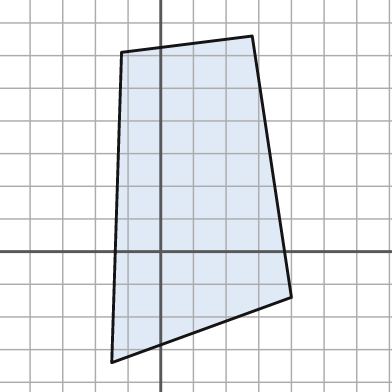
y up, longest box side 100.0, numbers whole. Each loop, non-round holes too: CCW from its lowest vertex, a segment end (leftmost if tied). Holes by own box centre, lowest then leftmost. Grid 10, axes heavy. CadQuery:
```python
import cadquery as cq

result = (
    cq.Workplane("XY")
    .moveTo(-15.0, -34.0)
    .lineTo(40.0, -14.0)
    .lineTo(28.0, 66.0)
    .lineTo(-12.0, 61.0)
    .close()
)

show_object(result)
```